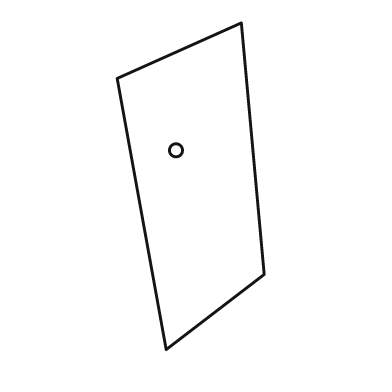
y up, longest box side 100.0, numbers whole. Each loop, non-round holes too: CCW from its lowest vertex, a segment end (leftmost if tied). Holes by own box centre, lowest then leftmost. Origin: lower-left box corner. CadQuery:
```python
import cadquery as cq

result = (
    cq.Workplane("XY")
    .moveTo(15.0, 0.0)
    .lineTo(45.0, 23.0)
    .lineTo(38.0, 100.0)
    .lineTo(0.0, 83.0)
    .close()
    .moveTo(18.0, 61.0)
    .circle(2.0)
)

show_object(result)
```